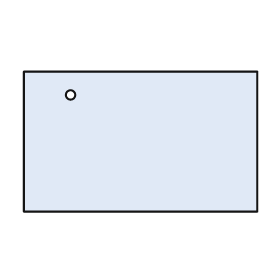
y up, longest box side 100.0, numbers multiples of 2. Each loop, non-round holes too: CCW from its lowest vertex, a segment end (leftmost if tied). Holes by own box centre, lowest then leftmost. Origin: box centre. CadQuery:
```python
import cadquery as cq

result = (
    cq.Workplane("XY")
    .moveTo(-50.0, -30.0)
    .lineTo(50.0, -30.0)
    .lineTo(50.0, 30.0)
    .lineTo(-50.0, 30.0)
    .close()
    .moveTo(-30.0, 20.0)
    .circle(2.0)
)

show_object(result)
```